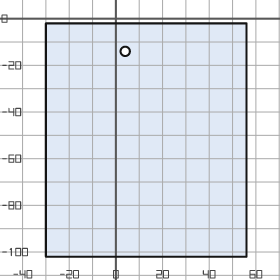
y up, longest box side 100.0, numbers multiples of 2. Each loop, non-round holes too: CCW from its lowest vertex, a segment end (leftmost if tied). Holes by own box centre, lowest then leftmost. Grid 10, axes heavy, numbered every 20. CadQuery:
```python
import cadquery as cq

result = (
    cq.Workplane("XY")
    .moveTo(-30.0, -102.0)
    .lineTo(56.0, -102.0)
    .lineTo(56.0, -2.0)
    .lineTo(-30.0, -2.0)
    .close()
    .moveTo(4.0, -14.0)
    .circle(2.0)
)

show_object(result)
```